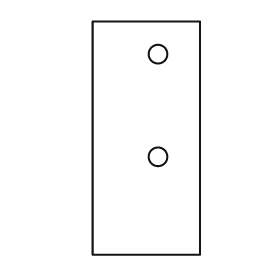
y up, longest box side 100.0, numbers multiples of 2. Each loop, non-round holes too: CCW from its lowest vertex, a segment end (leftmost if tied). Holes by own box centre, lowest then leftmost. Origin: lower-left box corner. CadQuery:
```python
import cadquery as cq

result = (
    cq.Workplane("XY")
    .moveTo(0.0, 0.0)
    .lineTo(46.0, 0.0)
    .lineTo(46.0, 100.0)
    .lineTo(0.0, 100.0)
    .close()
    .moveTo(28.0, 42.0)
    .circle(4.0)
    .moveTo(28.0, 86.0)
    .circle(4.0)
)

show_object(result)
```